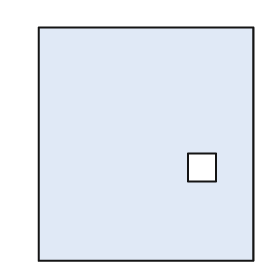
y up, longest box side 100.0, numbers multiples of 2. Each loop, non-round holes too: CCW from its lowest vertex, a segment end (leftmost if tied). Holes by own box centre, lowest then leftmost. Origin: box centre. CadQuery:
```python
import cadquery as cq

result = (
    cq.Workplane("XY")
    .moveTo(-46.0, -50.0)
    .lineTo(46.0, -50.0)
    .lineTo(46.0, 50.0)
    .lineTo(-46.0, 50.0)
    .close()
    .moveTo(18.0, -16.0)
    .lineTo(30.0, -16.0)
    .lineTo(30.0, -4.0)
    .lineTo(18.0, -4.0)
    .close()
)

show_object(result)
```